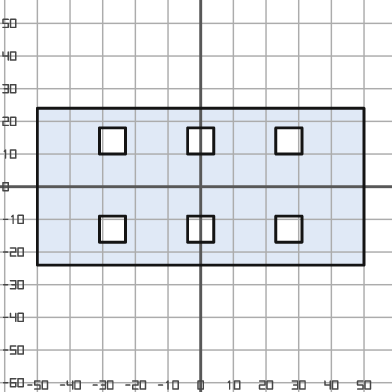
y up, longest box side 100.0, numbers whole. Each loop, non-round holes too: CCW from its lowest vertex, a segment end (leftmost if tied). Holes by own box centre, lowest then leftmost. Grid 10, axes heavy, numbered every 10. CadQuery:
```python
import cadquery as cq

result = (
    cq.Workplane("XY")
    .moveTo(-50.0, -24.0)
    .lineTo(50.0, -24.0)
    .lineTo(50.0, 24.0)
    .lineTo(-50.0, 24.0)
    .close()
    .moveTo(-31.0, -17.0)
    .lineTo(-23.0, -17.0)
    .lineTo(-23.0, -9.0)
    .lineTo(-31.0, -9.0)
    .close()
    .moveTo(-4.0, -17.0)
    .lineTo(4.0, -17.0)
    .lineTo(4.0, -9.0)
    .lineTo(-4.0, -9.0)
    .close()
    .moveTo(23.0, -17.0)
    .lineTo(31.0, -17.0)
    .lineTo(31.0, -9.0)
    .lineTo(23.0, -9.0)
    .close()
    .moveTo(-31.0, 10.0)
    .lineTo(-23.0, 10.0)
    .lineTo(-23.0, 18.0)
    .lineTo(-31.0, 18.0)
    .close()
    .moveTo(-4.0, 10.0)
    .lineTo(4.0, 10.0)
    .lineTo(4.0, 18.0)
    .lineTo(-4.0, 18.0)
    .close()
    .moveTo(23.0, 10.0)
    .lineTo(31.0, 10.0)
    .lineTo(31.0, 18.0)
    .lineTo(23.0, 18.0)
    .close()
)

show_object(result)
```